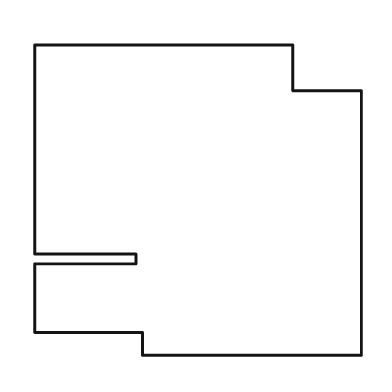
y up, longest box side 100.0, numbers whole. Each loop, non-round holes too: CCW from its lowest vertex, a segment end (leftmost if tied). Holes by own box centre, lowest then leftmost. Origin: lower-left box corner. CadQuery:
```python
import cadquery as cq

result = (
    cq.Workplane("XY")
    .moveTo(33.0, 0.0)
    .lineTo(100.0, 0.0)
    .lineTo(100.0, 81.0)
    .lineTo(79.0, 81.0)
    .lineTo(79.0, 95.0)
    .lineTo(0.0, 95.0)
    .lineTo(0.0, 31.0)
    .lineTo(31.0, 31.0)
    .lineTo(31.0, 28.0)
    .lineTo(0.0, 28.0)
    .lineTo(0.0, 7.0)
    .lineTo(33.0, 7.0)
    .close()
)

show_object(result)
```